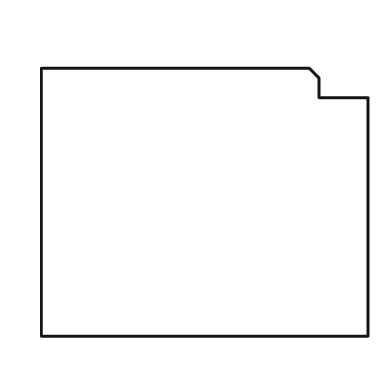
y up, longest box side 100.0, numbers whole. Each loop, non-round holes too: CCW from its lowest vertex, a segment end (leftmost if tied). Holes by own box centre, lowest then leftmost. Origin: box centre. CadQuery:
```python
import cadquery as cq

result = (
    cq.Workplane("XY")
    .moveTo(-50.0, -41.0)
    .lineTo(50.0, -41.0)
    .lineTo(50.0, 32.0)
    .lineTo(35.0, 32.0)
    .lineTo(35.0, 38.0)
    .lineTo(32.0, 41.0)
    .lineTo(-50.0, 41.0)
    .close()
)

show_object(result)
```